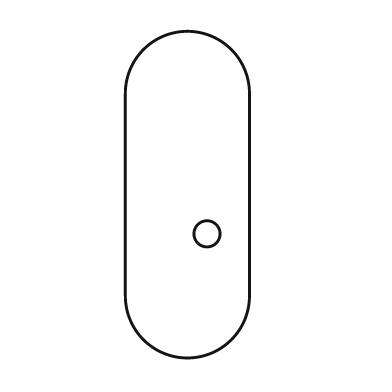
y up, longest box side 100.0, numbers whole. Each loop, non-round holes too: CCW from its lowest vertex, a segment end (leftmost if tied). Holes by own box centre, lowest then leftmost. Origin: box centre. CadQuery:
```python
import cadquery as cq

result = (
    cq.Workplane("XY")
    .moveTo(-19.0, -31.0)
    .threePointArc((0.0, -50.0), (19.0, -31.0))
    .lineTo(19.0, 31.0)
    .threePointArc((0.0, 50.0), (-19.0, 31.0))
    .close()
    .moveTo(6.0, -12.0)
    .circle(4.0)
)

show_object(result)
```